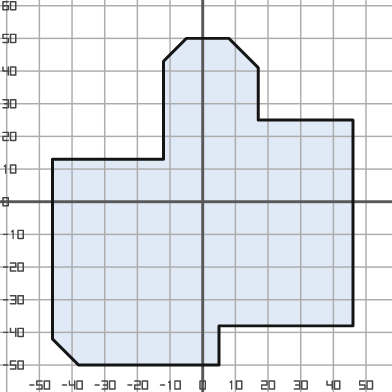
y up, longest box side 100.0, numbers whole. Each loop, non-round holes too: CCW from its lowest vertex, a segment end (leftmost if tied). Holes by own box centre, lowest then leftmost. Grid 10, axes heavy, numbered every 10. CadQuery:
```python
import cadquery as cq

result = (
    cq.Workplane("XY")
    .moveTo(-38.0, -50.0)
    .lineTo(5.0, -50.0)
    .lineTo(5.0, -38.0)
    .lineTo(46.0, -38.0)
    .lineTo(46.0, 25.0)
    .lineTo(17.0, 25.0)
    .lineTo(17.0, 41.0)
    .lineTo(8.0, 50.0)
    .lineTo(-5.0, 50.0)
    .lineTo(-12.0, 43.0)
    .lineTo(-12.0, 13.0)
    .lineTo(-46.0, 13.0)
    .lineTo(-46.0, -42.0)
    .close()
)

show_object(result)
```